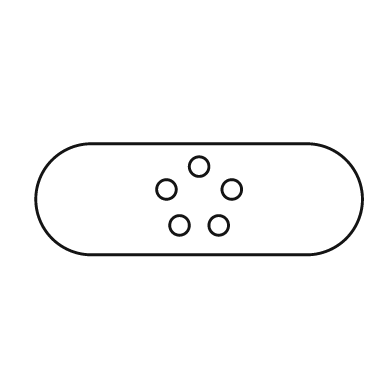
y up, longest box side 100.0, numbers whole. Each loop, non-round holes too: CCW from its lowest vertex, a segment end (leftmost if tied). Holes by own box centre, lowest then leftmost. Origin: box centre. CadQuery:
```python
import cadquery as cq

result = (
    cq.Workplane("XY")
    .moveTo(-33.0, -17.0)
    .lineTo(33.0, -17.0)
    .threePointArc((50.0, 0.0), (33.0, 17.0))
    .lineTo(-33.0, 17.0)
    .threePointArc((-50.0, 0.0), (-33.0, -17.0))
    .close()
    .moveTo(-6.0, -8.0)
    .circle(3.0)
    .moveTo(6.0, -8.0)
    .circle(3.0)
    .moveTo(-10.0, 3.0)
    .circle(3.0)
    .moveTo(10.0, 3.0)
    .circle(3.0)
    .moveTo(0.0, 10.0)
    .circle(3.0)
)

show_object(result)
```